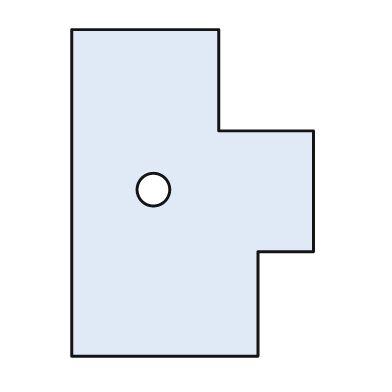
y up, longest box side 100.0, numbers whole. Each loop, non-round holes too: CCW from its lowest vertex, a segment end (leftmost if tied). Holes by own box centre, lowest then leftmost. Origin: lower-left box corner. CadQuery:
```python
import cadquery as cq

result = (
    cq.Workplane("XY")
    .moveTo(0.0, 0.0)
    .lineTo(57.0, 0.0)
    .lineTo(57.0, 32.0)
    .lineTo(74.0, 32.0)
    .lineTo(74.0, 69.0)
    .lineTo(45.0, 69.0)
    .lineTo(45.0, 100.0)
    .lineTo(0.0, 100.0)
    .close()
    .moveTo(25.0, 51.0)
    .circle(5.0)
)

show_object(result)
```